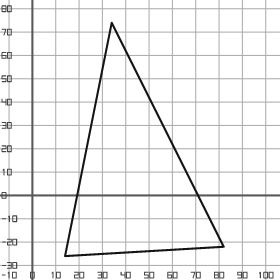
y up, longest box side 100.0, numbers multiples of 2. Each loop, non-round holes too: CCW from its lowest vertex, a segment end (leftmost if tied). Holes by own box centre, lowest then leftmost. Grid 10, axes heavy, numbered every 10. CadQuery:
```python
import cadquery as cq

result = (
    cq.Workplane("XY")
    .moveTo(14.0, -26.0)
    .lineTo(82.0, -22.0)
    .lineTo(34.0, 74.0)
    .close()
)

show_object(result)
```